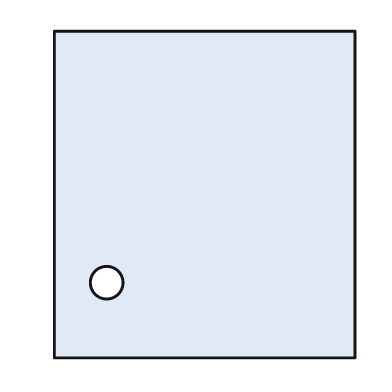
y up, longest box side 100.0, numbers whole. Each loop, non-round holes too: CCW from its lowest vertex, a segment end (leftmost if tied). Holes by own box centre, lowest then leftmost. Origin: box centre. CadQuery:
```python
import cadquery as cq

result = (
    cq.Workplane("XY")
    .moveTo(-46.0, -50.0)
    .lineTo(46.0, -50.0)
    .lineTo(46.0, 50.0)
    .lineTo(-46.0, 50.0)
    .close()
    .moveTo(-30.0, -27.0)
    .circle(5.0)
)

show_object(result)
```